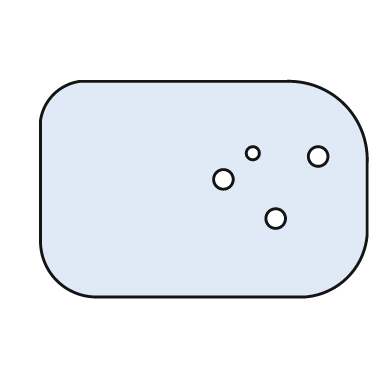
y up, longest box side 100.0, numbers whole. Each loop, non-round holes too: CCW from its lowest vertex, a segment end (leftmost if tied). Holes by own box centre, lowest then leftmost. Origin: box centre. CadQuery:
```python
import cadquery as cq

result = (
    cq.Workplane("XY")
    .moveTo(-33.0, -33.0)
    .lineTo(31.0, -33.0)
    .threePointArc((44.0, -27.0), (50.0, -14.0))
    .lineTo(50.0, 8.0)
    .threePointArc((43.0, 26.0), (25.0, 33.0))
    .lineTo(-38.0, 33.0)
    .threePointArc((-46.0, 29.0), (-50.0, 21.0))
    .lineTo(-50.0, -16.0)
    .threePointArc((-45.0, -28.0), (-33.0, -33.0))
    .close()
    .moveTo(22.0, -9.0)
    .circle(3.0)
    .moveTo(6.0, 3.0)
    .circle(3.0)
    .moveTo(35.0, 10.0)
    .circle(3.0)
    .moveTo(15.0, 11.0)
    .circle(2.0)
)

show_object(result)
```